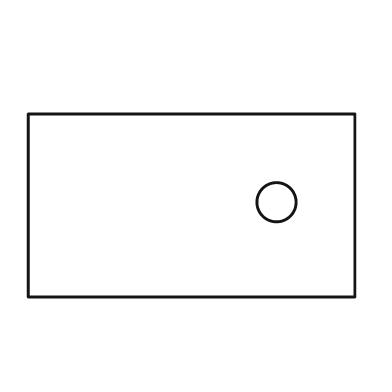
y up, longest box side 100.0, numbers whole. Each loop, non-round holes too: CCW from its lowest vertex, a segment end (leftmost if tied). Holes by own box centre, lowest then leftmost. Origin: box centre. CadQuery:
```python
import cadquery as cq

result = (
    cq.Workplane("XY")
    .moveTo(-50.0, -28.0)
    .lineTo(50.0, -28.0)
    .lineTo(50.0, 28.0)
    .lineTo(-50.0, 28.0)
    .close()
    .moveTo(26.0, 1.0)
    .circle(6.0)
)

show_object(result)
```